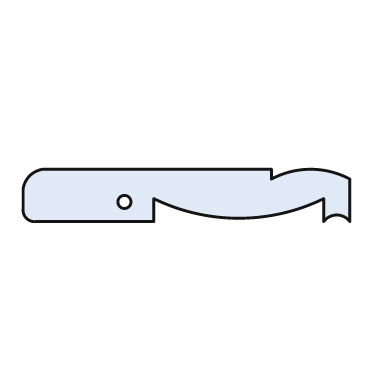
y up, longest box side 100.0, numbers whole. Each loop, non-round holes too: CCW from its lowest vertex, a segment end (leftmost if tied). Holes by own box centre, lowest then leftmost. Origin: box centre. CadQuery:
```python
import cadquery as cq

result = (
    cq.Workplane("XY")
    .moveTo(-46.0, -8.0)
    .lineTo(-10.0, -8.0)
    .lineTo(-10.0, -1.0)
    .threePointArc((16.0, -7.0), (42.0, -1.0))
    .lineTo(42.0, -8.0)
    .threePointArc((46.0, -6.0), (50.0, -8.0))
    .lineTo(50.0, 5.0)
    .threePointArc((38.0, 8.0), (26.0, 5.0))
    .lineTo(26.0, 8.0)
    .lineTo(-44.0, 8.0)
    .threePointArc((-48.0, 6.0), (-50.0, 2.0))
    .lineTo(-50.0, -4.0)
    .threePointArc((-49.0, -7.0), (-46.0, -8.0))
    .close()
    .moveTo(-19.0, -2.0)
    .circle(2.0)
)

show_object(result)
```